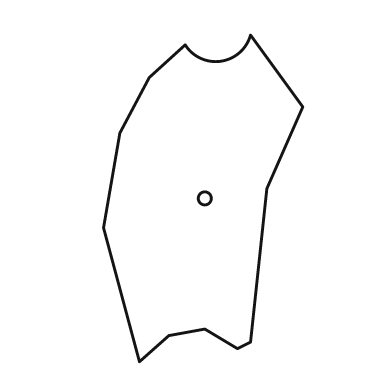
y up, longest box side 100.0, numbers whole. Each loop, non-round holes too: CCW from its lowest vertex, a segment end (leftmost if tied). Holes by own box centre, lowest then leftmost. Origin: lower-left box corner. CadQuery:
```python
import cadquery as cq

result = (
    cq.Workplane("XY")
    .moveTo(11.0, 0.0)
    .lineTo(20.0, 8.0)
    .lineTo(31.0, 10.0)
    .lineTo(41.0, 4.0)
    .lineTo(45.0, 6.0)
    .lineTo(50.0, 53.0)
    .lineTo(61.0, 78.0)
    .lineTo(45.0, 100.0)
    .threePointArc((36.0, 92.0), (25.0, 97.0))
    .lineTo(14.0, 87.0)
    .lineTo(5.0, 70.0)
    .lineTo(0.0, 41.0)
    .close()
    .moveTo(31.0, 50.0)
    .circle(2.0)
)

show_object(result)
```